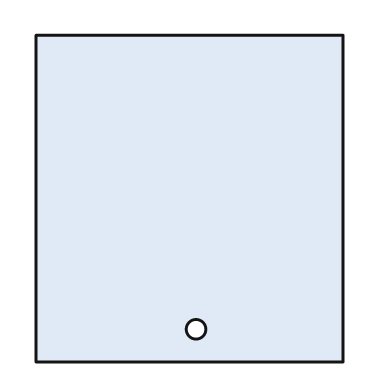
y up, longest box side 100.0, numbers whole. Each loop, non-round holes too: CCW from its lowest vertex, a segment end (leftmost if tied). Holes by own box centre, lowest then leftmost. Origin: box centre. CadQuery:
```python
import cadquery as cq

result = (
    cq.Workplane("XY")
    .moveTo(-47.0, -50.0)
    .lineTo(47.0, -50.0)
    .lineTo(47.0, 50.0)
    .lineTo(-47.0, 50.0)
    .close()
    .moveTo(2.0, -40.0)
    .circle(3.0)
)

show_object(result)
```